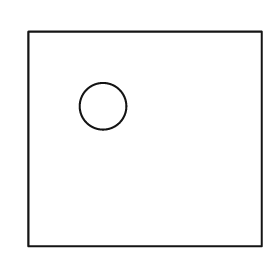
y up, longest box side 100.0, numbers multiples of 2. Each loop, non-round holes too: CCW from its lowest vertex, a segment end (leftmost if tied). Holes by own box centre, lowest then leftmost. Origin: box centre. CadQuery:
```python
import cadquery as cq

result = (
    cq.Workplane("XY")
    .moveTo(-50.0, -46.0)
    .lineTo(50.0, -46.0)
    .lineTo(50.0, 46.0)
    .lineTo(-50.0, 46.0)
    .close()
    .moveTo(-18.0, 14.0)
    .circle(10.0)
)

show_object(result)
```